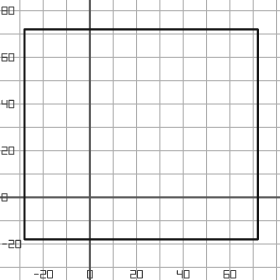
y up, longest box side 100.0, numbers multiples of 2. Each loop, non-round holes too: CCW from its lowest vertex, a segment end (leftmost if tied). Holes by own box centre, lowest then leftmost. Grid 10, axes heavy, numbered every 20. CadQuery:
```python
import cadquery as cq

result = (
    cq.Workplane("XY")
    .moveTo(-28.0, -18.0)
    .lineTo(72.0, -18.0)
    .lineTo(72.0, 72.0)
    .lineTo(-28.0, 72.0)
    .close()
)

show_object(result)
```